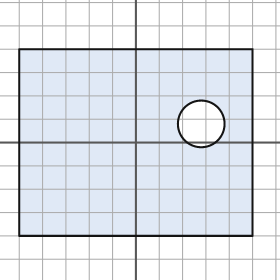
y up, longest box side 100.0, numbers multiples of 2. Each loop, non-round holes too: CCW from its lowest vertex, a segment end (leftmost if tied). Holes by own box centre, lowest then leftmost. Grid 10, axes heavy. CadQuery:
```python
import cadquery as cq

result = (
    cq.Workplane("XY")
    .moveTo(-50.0, -40.0)
    .lineTo(50.0, -40.0)
    .lineTo(50.0, 40.0)
    .lineTo(-50.0, 40.0)
    .close()
    .moveTo(28.0, 8.0)
    .circle(10.0)
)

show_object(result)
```